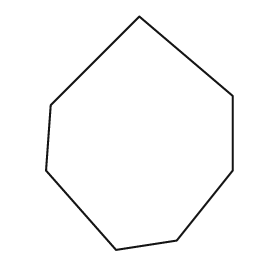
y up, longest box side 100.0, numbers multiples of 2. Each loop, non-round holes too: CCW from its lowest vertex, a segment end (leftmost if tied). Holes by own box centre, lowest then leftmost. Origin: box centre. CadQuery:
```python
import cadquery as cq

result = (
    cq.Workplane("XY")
    .moveTo(-10.0, -50.0)
    .lineTo(16.0, -46.0)
    .lineTo(40.0, -16.0)
    .lineTo(40.0, 16.0)
    .lineTo(0.0, 50.0)
    .lineTo(-38.0, 12.0)
    .lineTo(-40.0, -16.0)
    .close()
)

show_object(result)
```